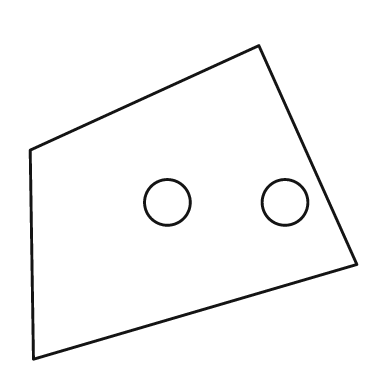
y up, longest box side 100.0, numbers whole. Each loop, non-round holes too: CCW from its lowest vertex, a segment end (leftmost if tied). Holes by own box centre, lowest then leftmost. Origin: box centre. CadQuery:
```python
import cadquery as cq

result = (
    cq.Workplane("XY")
    .moveTo(-49.0, -48.0)
    .lineTo(50.0, -19.0)
    .lineTo(20.0, 48.0)
    .lineTo(-50.0, 16.0)
    .close()
    .moveTo(-8.0, 0.0)
    .circle(7.0)
    .moveTo(28.0, 0.0)
    .circle(7.0)
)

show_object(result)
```